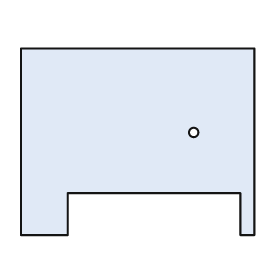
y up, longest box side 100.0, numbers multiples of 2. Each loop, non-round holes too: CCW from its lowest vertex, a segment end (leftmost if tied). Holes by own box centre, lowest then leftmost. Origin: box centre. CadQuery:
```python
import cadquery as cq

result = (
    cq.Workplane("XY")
    .moveTo(-50.0, -40.0)
    .lineTo(-30.0, -40.0)
    .lineTo(-30.0, -22.0)
    .lineTo(44.0, -22.0)
    .lineTo(44.0, -40.0)
    .lineTo(50.0, -40.0)
    .lineTo(50.0, 40.0)
    .lineTo(-50.0, 40.0)
    .close()
    .moveTo(24.0, 4.0)
    .circle(2.0)
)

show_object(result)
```